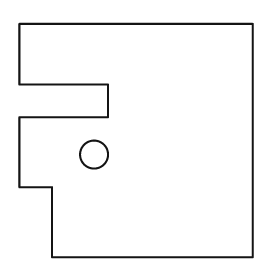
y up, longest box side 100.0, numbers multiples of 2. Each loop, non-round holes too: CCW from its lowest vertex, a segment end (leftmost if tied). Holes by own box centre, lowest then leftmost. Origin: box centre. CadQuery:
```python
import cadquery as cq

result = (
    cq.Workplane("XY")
    .moveTo(-36.0, -50.0)
    .lineTo(50.0, -50.0)
    .lineTo(50.0, 50.0)
    .lineTo(-50.0, 50.0)
    .lineTo(-50.0, 24.0)
    .lineTo(-12.0, 24.0)
    .lineTo(-12.0, 10.0)
    .lineTo(-50.0, 10.0)
    .lineTo(-50.0, -20.0)
    .lineTo(-36.0, -20.0)
    .close()
    .moveTo(-18.0, -6.0)
    .circle(6.0)
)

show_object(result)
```